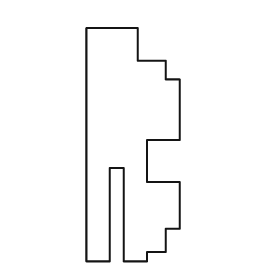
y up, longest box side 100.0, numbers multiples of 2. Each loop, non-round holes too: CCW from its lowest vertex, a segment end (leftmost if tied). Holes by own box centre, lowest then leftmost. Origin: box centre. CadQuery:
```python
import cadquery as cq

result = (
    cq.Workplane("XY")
    .moveTo(-20.0, -50.0)
    .lineTo(-10.0, -50.0)
    .lineTo(-10.0, -10.0)
    .lineTo(-4.0, -10.0)
    .lineTo(-4.0, -50.0)
    .lineTo(6.0, -50.0)
    .lineTo(6.0, -46.0)
    .lineTo(14.0, -46.0)
    .lineTo(14.0, -36.0)
    .lineTo(20.0, -36.0)
    .lineTo(20.0, -16.0)
    .lineTo(6.0, -16.0)
    .lineTo(6.0, 2.0)
    .lineTo(20.0, 2.0)
    .lineTo(20.0, 28.0)
    .lineTo(14.0, 28.0)
    .lineTo(14.0, 36.0)
    .lineTo(2.0, 36.0)
    .lineTo(2.0, 50.0)
    .lineTo(-20.0, 50.0)
    .close()
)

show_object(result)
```